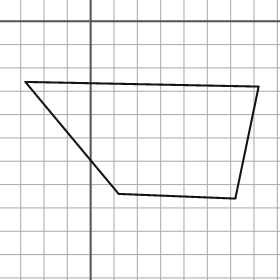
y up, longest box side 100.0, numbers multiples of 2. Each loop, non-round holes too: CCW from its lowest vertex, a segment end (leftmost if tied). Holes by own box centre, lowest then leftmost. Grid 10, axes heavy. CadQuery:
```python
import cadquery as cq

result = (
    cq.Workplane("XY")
    .moveTo(62.0, -76.0)
    .lineTo(72.0, -28.0)
    .lineTo(-28.0, -26.0)
    .lineTo(12.0, -74.0)
    .close()
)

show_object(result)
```